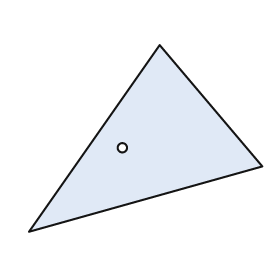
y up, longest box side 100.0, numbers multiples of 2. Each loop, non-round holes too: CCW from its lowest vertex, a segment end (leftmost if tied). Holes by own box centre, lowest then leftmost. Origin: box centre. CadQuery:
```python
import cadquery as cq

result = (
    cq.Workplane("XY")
    .moveTo(-50.0, -40.0)
    .lineTo(50.0, -12.0)
    .lineTo(6.0, 40.0)
    .close()
    .moveTo(-10.0, -4.0)
    .circle(2.0)
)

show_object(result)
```